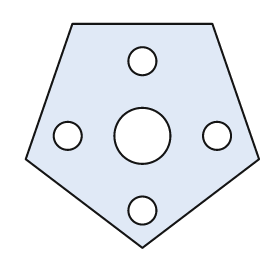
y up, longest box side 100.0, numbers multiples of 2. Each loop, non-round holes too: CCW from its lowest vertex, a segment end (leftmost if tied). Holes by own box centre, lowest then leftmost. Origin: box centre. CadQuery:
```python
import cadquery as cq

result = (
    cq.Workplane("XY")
    .moveTo(0.0, -48.0)
    .lineTo(50.0, -10.0)
    .lineTo(30.0, 48.0)
    .lineTo(-30.0, 48.0)
    .lineTo(-50.0, -10.0)
    .close()
    .moveTo(0.0, -32.0)
    .circle(6.0)
    .moveTo(-32.0, 0.0)
    .circle(6.0)
    .moveTo(0.0, 0.0)
    .circle(12.0)
    .moveTo(32.0, 0.0)
    .circle(6.0)
    .moveTo(0.0, 32.0)
    .circle(6.0)
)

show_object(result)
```